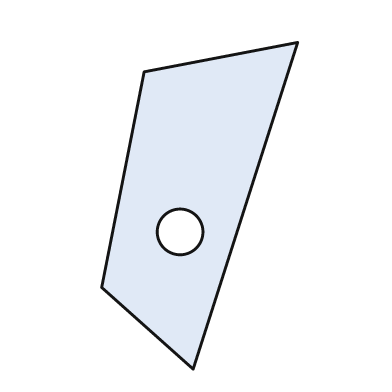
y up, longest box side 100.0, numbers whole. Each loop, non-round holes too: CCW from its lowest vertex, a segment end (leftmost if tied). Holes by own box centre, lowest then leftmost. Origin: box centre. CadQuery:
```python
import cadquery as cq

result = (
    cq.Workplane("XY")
    .moveTo(-2.0, -50.0)
    .lineTo(30.0, 50.0)
    .lineTo(-17.0, 41.0)
    .lineTo(-30.0, -25.0)
    .close()
    .moveTo(-6.0, -8.0)
    .circle(7.0)
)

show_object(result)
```